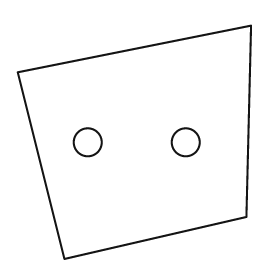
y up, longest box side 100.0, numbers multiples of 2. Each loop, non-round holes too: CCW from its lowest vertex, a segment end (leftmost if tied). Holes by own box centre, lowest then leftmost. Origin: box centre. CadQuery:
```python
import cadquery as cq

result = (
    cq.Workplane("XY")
    .moveTo(-30.0, -50.0)
    .lineTo(48.0, -32.0)
    .lineTo(50.0, 50.0)
    .lineTo(-50.0, 30.0)
    .close()
    .moveTo(-20.0, 0.0)
    .circle(6.0)
    .moveTo(22.0, 0.0)
    .circle(6.0)
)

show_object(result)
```